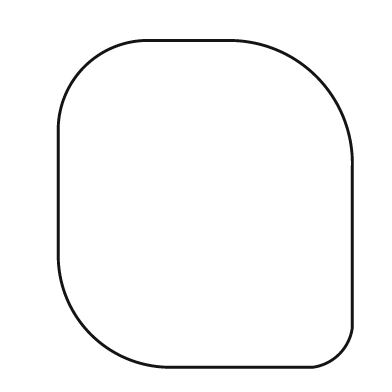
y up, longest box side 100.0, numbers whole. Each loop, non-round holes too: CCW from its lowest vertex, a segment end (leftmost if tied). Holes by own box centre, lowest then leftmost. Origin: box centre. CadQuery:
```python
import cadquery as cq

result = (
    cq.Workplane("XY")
    .moveTo(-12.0, -50.0)
    .lineTo(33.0, -50.0)
    .threePointArc((41.0, -46.0), (45.0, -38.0))
    .lineTo(45.0, 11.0)
    .threePointArc((34.0, 39.0), (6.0, 50.0))
    .lineTo(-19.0, 50.0)
    .threePointArc((-37.0, 42.0), (-45.0, 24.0))
    .lineTo(-45.0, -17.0)
    .threePointArc((-35.0, -40.0), (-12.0, -50.0))
    .close()
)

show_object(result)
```